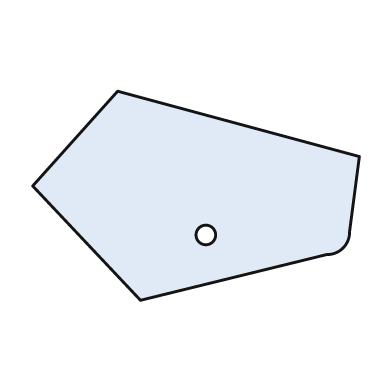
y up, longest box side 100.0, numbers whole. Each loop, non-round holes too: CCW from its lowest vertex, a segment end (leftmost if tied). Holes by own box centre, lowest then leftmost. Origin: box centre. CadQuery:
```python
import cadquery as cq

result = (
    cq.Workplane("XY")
    .moveTo(-17.0, -32.0)
    .lineTo(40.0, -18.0)
    .threePointArc((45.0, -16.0), (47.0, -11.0))
    .lineTo(50.0, 12.0)
    .lineTo(-24.0, 32.0)
    .lineTo(-50.0, 3.0)
    .close()
    .moveTo(3.0, -12.0)
    .circle(3.0)
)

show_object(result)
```